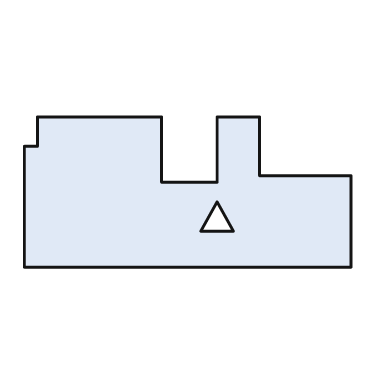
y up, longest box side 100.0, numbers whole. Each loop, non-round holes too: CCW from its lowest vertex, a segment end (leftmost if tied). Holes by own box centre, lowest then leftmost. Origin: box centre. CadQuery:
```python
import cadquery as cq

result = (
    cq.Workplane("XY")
    .moveTo(-50.0, -23.0)
    .lineTo(50.0, -23.0)
    .lineTo(50.0, 5.0)
    .lineTo(22.0, 5.0)
    .lineTo(22.0, 23.0)
    .lineTo(9.0, 23.0)
    .lineTo(9.0, 3.0)
    .lineTo(-8.0, 3.0)
    .lineTo(-8.0, 23.0)
    .lineTo(-46.0, 23.0)
    .lineTo(-46.0, 14.0)
    .lineTo(-50.0, 14.0)
    .close()
    .moveTo(4.0, -12.0)
    .lineTo(14.0, -12.0)
    .lineTo(9.0, -3.0)
    .close()
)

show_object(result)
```